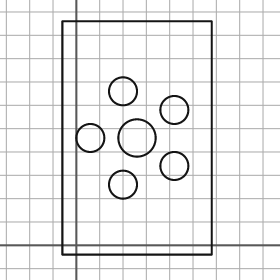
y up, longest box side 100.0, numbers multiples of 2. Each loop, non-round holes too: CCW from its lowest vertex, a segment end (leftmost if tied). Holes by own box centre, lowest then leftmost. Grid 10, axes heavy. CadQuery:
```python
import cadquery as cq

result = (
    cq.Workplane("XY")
    .moveTo(-6.0, -4.0)
    .lineTo(58.0, -4.0)
    .lineTo(58.0, 96.0)
    .lineTo(-6.0, 96.0)
    .close()
    .moveTo(20.0, 26.0)
    .circle(6.0)
    .moveTo(42.0, 34.0)
    .circle(6.0)
    .moveTo(6.0, 46.0)
    .circle(6.0)
    .moveTo(26.0, 46.0)
    .circle(8.0)
    .moveTo(42.0, 58.0)
    .circle(6.0)
    .moveTo(20.0, 66.0)
    .circle(6.0)
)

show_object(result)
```